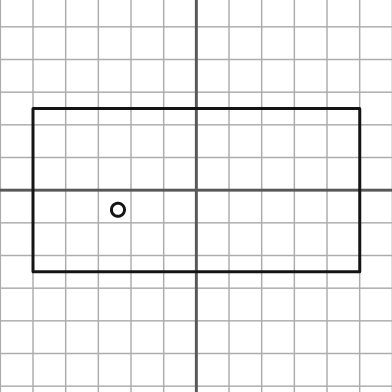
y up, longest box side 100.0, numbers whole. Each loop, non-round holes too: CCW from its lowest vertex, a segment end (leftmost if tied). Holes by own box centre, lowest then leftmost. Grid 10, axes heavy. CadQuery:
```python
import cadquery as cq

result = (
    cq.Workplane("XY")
    .moveTo(-50.0, -25.0)
    .lineTo(50.0, -25.0)
    .lineTo(50.0, 25.0)
    .lineTo(-50.0, 25.0)
    .close()
    .moveTo(-24.0, -6.0)
    .circle(2.0)
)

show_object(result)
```